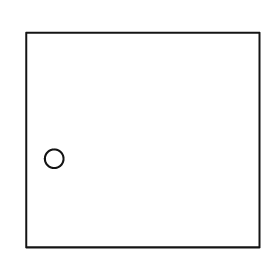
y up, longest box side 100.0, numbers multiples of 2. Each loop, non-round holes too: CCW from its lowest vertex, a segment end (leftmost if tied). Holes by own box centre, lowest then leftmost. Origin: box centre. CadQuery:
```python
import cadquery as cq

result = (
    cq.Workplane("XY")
    .moveTo(-50.0, -46.0)
    .lineTo(50.0, -46.0)
    .lineTo(50.0, 46.0)
    .lineTo(-50.0, 46.0)
    .close()
    .moveTo(-38.0, -8.0)
    .circle(4.0)
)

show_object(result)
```